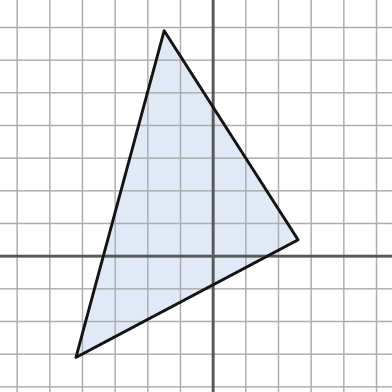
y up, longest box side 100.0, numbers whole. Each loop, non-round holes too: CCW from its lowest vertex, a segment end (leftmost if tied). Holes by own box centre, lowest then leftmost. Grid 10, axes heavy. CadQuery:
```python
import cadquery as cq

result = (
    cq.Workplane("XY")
    .moveTo(-42.0, -31.0)
    .lineTo(26.0, 5.0)
    .lineTo(-15.0, 69.0)
    .close()
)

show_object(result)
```